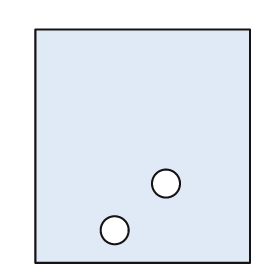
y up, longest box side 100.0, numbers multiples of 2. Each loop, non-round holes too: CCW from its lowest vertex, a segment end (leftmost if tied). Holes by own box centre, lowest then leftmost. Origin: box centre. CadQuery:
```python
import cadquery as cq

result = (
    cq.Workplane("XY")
    .moveTo(-46.0, -50.0)
    .lineTo(46.0, -50.0)
    .lineTo(46.0, 50.0)
    .lineTo(-46.0, 50.0)
    .close()
    .moveTo(-12.0, -36.0)
    .circle(6.0)
    .moveTo(10.0, -16.0)
    .circle(6.0)
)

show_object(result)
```